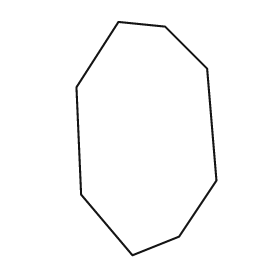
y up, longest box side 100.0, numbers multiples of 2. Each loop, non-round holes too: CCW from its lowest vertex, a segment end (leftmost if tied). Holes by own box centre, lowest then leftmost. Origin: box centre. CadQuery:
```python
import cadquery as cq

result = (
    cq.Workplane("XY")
    .moveTo(-6.0, -50.0)
    .lineTo(14.0, -42.0)
    .lineTo(30.0, -18.0)
    .lineTo(26.0, 30.0)
    .lineTo(8.0, 48.0)
    .lineTo(-12.0, 50.0)
    .lineTo(-30.0, 22.0)
    .lineTo(-28.0, -24.0)
    .close()
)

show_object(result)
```